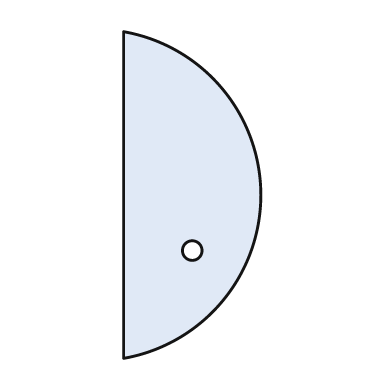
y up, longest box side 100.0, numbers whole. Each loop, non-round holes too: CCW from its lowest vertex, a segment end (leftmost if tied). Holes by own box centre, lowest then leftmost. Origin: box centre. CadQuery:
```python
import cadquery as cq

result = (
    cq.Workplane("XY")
    .moveTo(-21.0, -50.0)
    .threePointArc((21.0, 0.0), (-21.0, 50.0))
    .close()
    .moveTo(0.0, -17.0)
    .circle(3.0)
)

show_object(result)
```